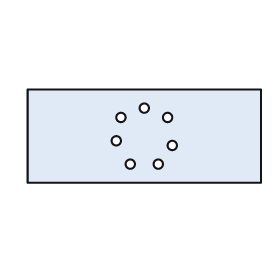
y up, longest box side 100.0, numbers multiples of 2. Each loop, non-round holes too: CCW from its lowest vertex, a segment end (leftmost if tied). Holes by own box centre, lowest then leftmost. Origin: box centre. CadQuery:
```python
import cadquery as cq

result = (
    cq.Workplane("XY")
    .moveTo(-50.0, -20.0)
    .lineTo(50.0, -20.0)
    .lineTo(50.0, 20.0)
    .lineTo(-50.0, 20.0)
    .close()
    .moveTo(-6.0, -12.0)
    .circle(2.0)
    .moveTo(6.0, -12.0)
    .circle(2.0)
    .moveTo(12.0, -4.0)
    .circle(2.0)
    .moveTo(-12.0, -2.0)
    .circle(2.0)
    .moveTo(-10.0, 8.0)
    .circle(2.0)
    .moveTo(10.0, 8.0)
    .circle(2.0)
    .moveTo(0.0, 12.0)
    .circle(2.0)
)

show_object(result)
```